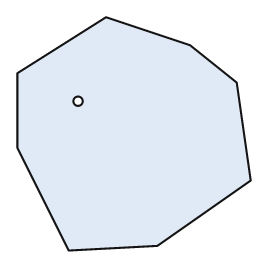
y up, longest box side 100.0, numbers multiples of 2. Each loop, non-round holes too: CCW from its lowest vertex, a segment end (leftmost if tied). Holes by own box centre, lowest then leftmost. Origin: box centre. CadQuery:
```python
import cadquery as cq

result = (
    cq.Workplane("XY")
    .moveTo(-28.0, -50.0)
    .lineTo(10.0, -48.0)
    .lineTo(50.0, -20.0)
    .lineTo(44.0, 22.0)
    .lineTo(24.0, 38.0)
    .lineTo(-12.0, 50.0)
    .lineTo(-50.0, 26.0)
    .lineTo(-50.0, -6.0)
    .close()
    .moveTo(-24.0, 14.0)
    .circle(2.0)
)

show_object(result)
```